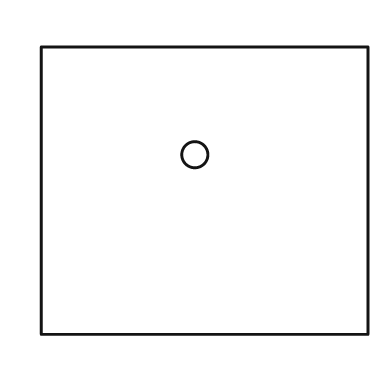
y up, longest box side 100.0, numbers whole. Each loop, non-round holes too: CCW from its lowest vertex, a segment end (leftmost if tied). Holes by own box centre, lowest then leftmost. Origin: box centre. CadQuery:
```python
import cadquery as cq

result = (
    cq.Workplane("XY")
    .moveTo(-50.0, -44.0)
    .lineTo(50.0, -44.0)
    .lineTo(50.0, 44.0)
    .lineTo(-50.0, 44.0)
    .close()
    .moveTo(-3.0, 11.0)
    .circle(4.0)
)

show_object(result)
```